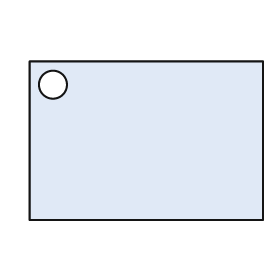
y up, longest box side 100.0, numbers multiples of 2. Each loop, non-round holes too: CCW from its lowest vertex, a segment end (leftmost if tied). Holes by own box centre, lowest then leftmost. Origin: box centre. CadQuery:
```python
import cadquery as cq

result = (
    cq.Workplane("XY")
    .moveTo(-50.0, -34.0)
    .lineTo(50.0, -34.0)
    .lineTo(50.0, 34.0)
    .lineTo(-50.0, 34.0)
    .close()
    .moveTo(-40.0, 24.0)
    .circle(6.0)
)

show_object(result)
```